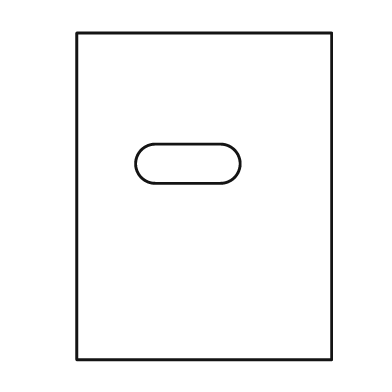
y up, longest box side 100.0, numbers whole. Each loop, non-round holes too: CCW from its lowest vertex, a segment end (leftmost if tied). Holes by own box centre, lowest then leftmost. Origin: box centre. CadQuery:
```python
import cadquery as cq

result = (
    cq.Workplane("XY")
    .moveTo(-39.0, -50.0)
    .lineTo(39.0, -50.0)
    .lineTo(39.0, 50.0)
    .lineTo(-39.0, 50.0)
    .close()
    .moveTo(-15.0, 4.0)
    .lineTo(5.0, 4.0)
    .threePointArc((11.0, 10.0), (5.0, 16.0))
    .lineTo(-15.0, 16.0)
    .threePointArc((-21.0, 10.0), (-15.0, 4.0))
    .close()
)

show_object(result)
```